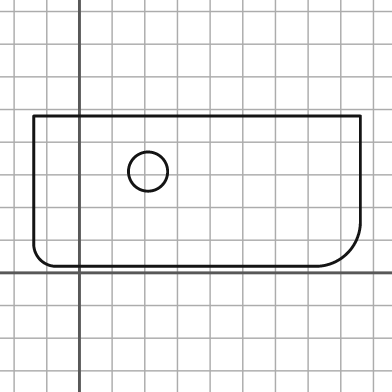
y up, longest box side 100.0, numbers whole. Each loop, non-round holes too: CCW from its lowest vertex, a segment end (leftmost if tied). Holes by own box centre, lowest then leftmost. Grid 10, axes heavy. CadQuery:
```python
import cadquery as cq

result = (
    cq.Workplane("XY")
    .moveTo(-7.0, 2.0)
    .lineTo(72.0, 2.0)
    .threePointArc((82.0, 6.0), (86.0, 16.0))
    .lineTo(86.0, 48.0)
    .lineTo(-14.0, 48.0)
    .lineTo(-14.0, 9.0)
    .threePointArc((-12.0, 4.0), (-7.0, 2.0))
    .close()
    .moveTo(21.0, 31.0)
    .circle(6.0)
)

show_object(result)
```